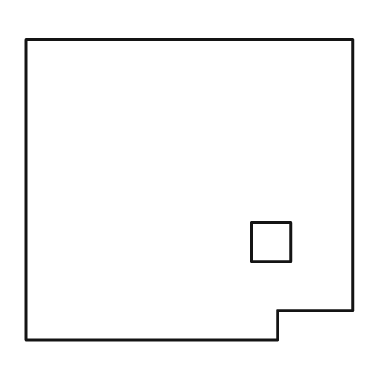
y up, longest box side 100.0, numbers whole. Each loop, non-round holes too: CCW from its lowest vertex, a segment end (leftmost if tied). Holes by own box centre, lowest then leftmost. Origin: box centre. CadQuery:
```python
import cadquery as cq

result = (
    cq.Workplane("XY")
    .moveTo(-50.0, -46.0)
    .lineTo(27.0, -46.0)
    .lineTo(27.0, -37.0)
    .lineTo(50.0, -37.0)
    .lineTo(50.0, 46.0)
    .lineTo(-50.0, 46.0)
    .close()
    .moveTo(19.0, -22.0)
    .lineTo(31.0, -22.0)
    .lineTo(31.0, -10.0)
    .lineTo(19.0, -10.0)
    .close()
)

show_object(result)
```